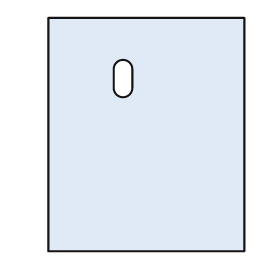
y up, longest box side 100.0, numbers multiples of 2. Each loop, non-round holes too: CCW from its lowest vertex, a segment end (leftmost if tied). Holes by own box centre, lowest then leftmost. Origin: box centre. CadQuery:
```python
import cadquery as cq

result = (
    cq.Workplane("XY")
    .moveTo(-42.0, -50.0)
    .lineTo(42.0, -50.0)
    .lineTo(42.0, 50.0)
    .lineTo(-42.0, 50.0)
    .close()
    .moveTo(-14.0, 20.0)
    .threePointArc((-10.0, 16.0), (-6.0, 20.0))
    .lineTo(-6.0, 28.0)
    .threePointArc((-10.0, 32.0), (-14.0, 28.0))
    .close()
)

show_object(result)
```